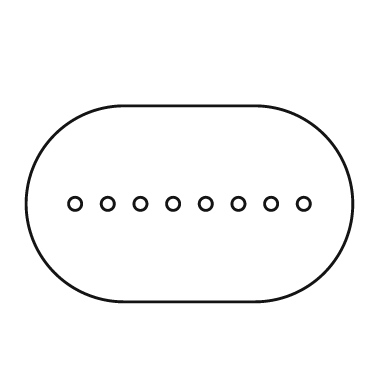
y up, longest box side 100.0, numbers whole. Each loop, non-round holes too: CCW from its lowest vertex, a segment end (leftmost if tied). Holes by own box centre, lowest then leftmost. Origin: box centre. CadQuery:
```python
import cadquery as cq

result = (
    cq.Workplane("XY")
    .moveTo(-20.0, -30.0)
    .lineTo(20.0, -30.0)
    .threePointArc((50.0, 0.0), (20.0, 30.0))
    .lineTo(-20.0, 30.0)
    .threePointArc((-50.0, 0.0), (-20.0, -30.0))
    .close()
    .moveTo(-35.0, 0.0)
    .circle(2.0)
    .moveTo(-25.0, 0.0)
    .circle(2.0)
    .moveTo(-15.0, 0.0)
    .circle(2.0)
    .moveTo(-5.0, 0.0)
    .circle(2.0)
    .moveTo(5.0, 0.0)
    .circle(2.0)
    .moveTo(15.0, 0.0)
    .circle(2.0)
    .moveTo(25.0, 0.0)
    .circle(2.0)
    .moveTo(35.0, 0.0)
    .circle(2.0)
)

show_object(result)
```